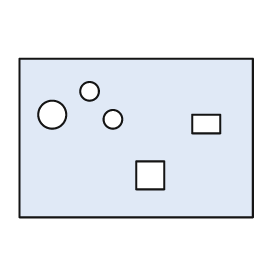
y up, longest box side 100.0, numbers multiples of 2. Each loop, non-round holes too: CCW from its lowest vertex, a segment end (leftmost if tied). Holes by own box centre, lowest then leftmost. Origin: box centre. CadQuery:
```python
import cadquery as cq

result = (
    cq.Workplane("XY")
    .moveTo(-50.0, -34.0)
    .lineTo(50.0, -34.0)
    .lineTo(50.0, 34.0)
    .lineTo(-50.0, 34.0)
    .close()
    .moveTo(0.0, -22.0)
    .lineTo(12.0, -22.0)
    .lineTo(12.0, -10.0)
    .lineTo(0.0, -10.0)
    .close()
    .moveTo(24.0, 2.0)
    .lineTo(36.0, 2.0)
    .lineTo(36.0, 10.0)
    .lineTo(24.0, 10.0)
    .close()
    .moveTo(-10.0, 8.0)
    .circle(4.0)
    .moveTo(-36.0, 10.0)
    .circle(6.0)
    .moveTo(-20.0, 20.0)
    .circle(4.0)
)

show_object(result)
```